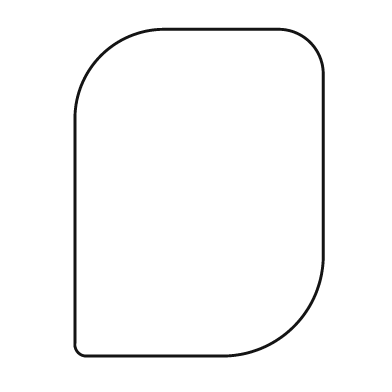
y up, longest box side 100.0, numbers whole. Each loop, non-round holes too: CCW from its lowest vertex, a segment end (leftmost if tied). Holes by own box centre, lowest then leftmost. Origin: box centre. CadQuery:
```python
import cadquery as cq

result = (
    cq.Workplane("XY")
    .moveTo(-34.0, -50.0)
    .lineTo(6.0, -50.0)
    .threePointArc((29.0, -41.0), (38.0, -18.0))
    .lineTo(38.0, 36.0)
    .threePointArc((34.0, 46.0), (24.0, 50.0))
    .lineTo(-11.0, 50.0)
    .threePointArc((-30.0, 42.0), (-38.0, 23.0))
    .lineTo(-38.0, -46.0)
    .threePointArc((-37.0, -49.0), (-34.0, -50.0))
    .close()
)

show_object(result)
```